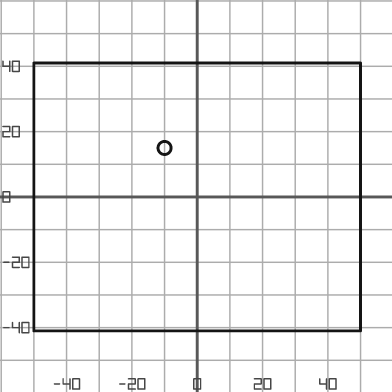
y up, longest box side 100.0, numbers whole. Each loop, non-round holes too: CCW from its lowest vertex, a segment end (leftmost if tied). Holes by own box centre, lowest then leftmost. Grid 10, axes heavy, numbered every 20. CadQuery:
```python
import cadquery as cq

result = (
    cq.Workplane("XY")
    .moveTo(-50.0, -41.0)
    .lineTo(50.0, -41.0)
    .lineTo(50.0, 41.0)
    .lineTo(-50.0, 41.0)
    .close()
    .moveTo(-10.0, 15.0)
    .circle(2.0)
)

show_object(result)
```